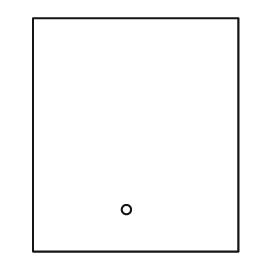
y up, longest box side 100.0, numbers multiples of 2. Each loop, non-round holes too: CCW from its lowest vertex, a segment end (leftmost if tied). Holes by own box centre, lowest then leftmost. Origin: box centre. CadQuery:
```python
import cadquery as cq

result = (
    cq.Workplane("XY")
    .moveTo(-44.0, -50.0)
    .lineTo(44.0, -50.0)
    .lineTo(44.0, 50.0)
    .lineTo(-44.0, 50.0)
    .close()
    .moveTo(-4.0, -32.0)
    .circle(2.0)
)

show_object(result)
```